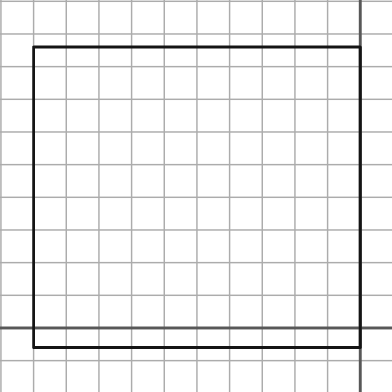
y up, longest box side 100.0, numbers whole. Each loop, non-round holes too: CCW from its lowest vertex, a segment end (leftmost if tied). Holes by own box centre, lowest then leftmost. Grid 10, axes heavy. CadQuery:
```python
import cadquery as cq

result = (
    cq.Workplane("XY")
    .moveTo(-100.0, -6.0)
    .lineTo(0.0, -6.0)
    .lineTo(0.0, 86.0)
    .lineTo(-100.0, 86.0)
    .close()
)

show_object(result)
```